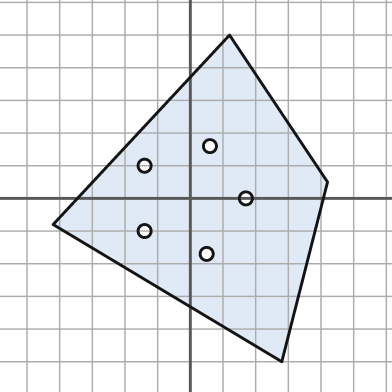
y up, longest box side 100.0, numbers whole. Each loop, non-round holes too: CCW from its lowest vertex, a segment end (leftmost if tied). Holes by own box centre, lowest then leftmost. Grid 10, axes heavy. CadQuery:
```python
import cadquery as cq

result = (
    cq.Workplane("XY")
    .moveTo(28.0, -50.0)
    .lineTo(42.0, 5.0)
    .lineTo(12.0, 50.0)
    .lineTo(-42.0, -8.0)
    .close()
    .moveTo(5.0, -17.0)
    .circle(2.0)
    .moveTo(-14.0, -10.0)
    .circle(2.0)
    .moveTo(17.0, 0.0)
    .circle(2.0)
    .moveTo(-14.0, 10.0)
    .circle(2.0)
    .moveTo(6.0, 16.0)
    .circle(2.0)
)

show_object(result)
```